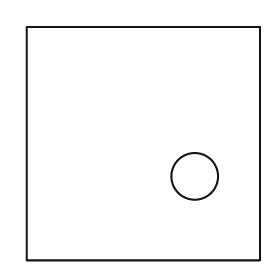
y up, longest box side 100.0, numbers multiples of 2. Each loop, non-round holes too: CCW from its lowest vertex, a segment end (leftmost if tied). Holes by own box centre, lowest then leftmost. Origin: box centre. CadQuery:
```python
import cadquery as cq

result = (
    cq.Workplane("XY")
    .moveTo(-50.0, -50.0)
    .lineTo(50.0, -50.0)
    .lineTo(50.0, 50.0)
    .lineTo(-50.0, 50.0)
    .close()
    .moveTo(22.0, -14.0)
    .circle(10.0)
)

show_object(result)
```